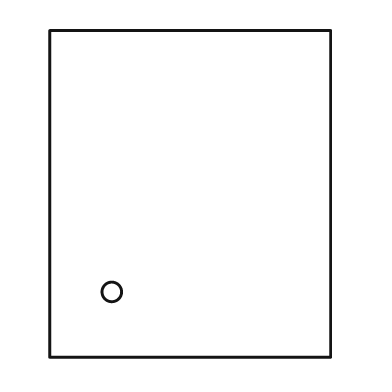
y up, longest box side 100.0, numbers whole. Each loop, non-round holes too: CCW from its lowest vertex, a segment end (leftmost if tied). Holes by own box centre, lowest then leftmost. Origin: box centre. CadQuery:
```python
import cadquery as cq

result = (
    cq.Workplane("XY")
    .moveTo(-43.0, -50.0)
    .lineTo(43.0, -50.0)
    .lineTo(43.0, 50.0)
    .lineTo(-43.0, 50.0)
    .close()
    .moveTo(-24.0, -30.0)
    .circle(3.0)
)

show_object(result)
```